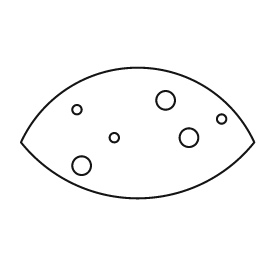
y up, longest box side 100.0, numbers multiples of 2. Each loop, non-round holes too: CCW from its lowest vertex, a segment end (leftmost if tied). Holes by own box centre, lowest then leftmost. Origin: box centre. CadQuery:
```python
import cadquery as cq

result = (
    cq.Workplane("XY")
    .moveTo(-50.0, -4.0)
    .threePointArc((0.0, -28.0), (50.0, -4.0))
    .threePointArc((0.0, 28.0), (-50.0, -4.0))
    .close()
    .moveTo(-24.0, -14.0)
    .circle(4.0)
    .moveTo(-10.0, -2.0)
    .circle(2.0)
    .moveTo(22.0, -2.0)
    .circle(4.0)
    .moveTo(36.0, 6.0)
    .circle(2.0)
    .moveTo(-26.0, 10.0)
    .circle(2.0)
    .moveTo(12.0, 14.0)
    .circle(4.0)
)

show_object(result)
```